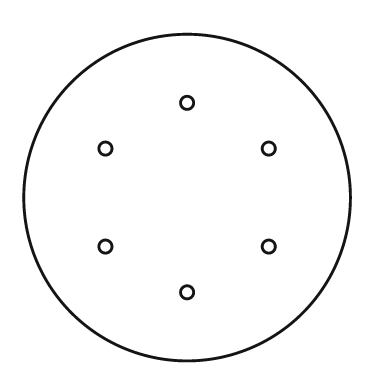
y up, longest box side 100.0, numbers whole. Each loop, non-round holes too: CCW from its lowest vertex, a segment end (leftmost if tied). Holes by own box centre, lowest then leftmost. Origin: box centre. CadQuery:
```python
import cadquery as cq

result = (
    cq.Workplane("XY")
    .moveTo(0.0, 0.0)
    .circle(50.0)
    .moveTo(0.0, -29.0)
    .circle(2.0)
    .moveTo(-25.0, -15.0)
    .circle(2.0)
    .moveTo(25.0, -15.0)
    .circle(2.0)
    .moveTo(-25.0, 15.0)
    .circle(2.0)
    .moveTo(25.0, 15.0)
    .circle(2.0)
    .moveTo(0.0, 29.0)
    .circle(2.0)
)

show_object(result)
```